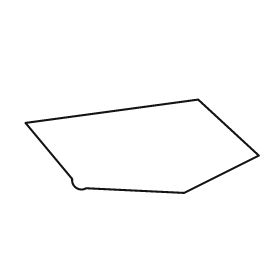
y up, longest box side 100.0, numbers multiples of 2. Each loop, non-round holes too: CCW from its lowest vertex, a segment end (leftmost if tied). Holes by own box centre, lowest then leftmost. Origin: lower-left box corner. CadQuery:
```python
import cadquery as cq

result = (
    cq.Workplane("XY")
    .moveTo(68.0, 0.0)
    .lineTo(100.0, 16.0)
    .lineTo(74.0, 40.0)
    .lineTo(0.0, 30.0)
    .lineTo(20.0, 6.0)
    .threePointArc((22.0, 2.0), (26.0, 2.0))
    .close()
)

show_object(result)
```